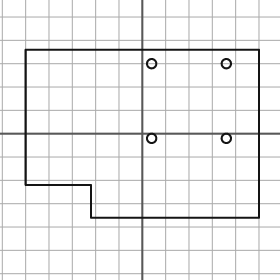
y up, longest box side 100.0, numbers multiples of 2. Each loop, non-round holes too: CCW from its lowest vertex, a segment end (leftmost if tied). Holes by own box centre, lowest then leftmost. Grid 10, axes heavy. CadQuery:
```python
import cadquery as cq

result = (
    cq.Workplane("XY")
    .moveTo(-22.0, -36.0)
    .lineTo(50.0, -36.0)
    .lineTo(50.0, 36.0)
    .lineTo(-50.0, 36.0)
    .lineTo(-50.0, -22.0)
    .lineTo(-22.0, -22.0)
    .close()
    .moveTo(4.0, -2.0)
    .circle(2.0)
    .moveTo(36.0, -2.0)
    .circle(2.0)
    .moveTo(4.0, 30.0)
    .circle(2.0)
    .moveTo(36.0, 30.0)
    .circle(2.0)
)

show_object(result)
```